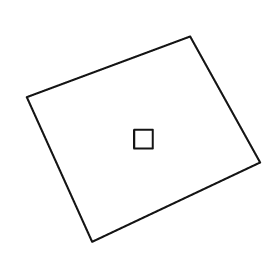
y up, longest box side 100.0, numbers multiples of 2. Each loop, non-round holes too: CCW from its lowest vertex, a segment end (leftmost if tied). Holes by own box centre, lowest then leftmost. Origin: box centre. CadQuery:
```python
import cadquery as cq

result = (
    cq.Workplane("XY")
    .moveTo(-22.0, -44.0)
    .lineTo(50.0, -10.0)
    .lineTo(20.0, 44.0)
    .lineTo(-50.0, 18.0)
    .close()
    .moveTo(-4.0, -4.0)
    .lineTo(4.0, -4.0)
    .lineTo(4.0, 4.0)
    .lineTo(-4.0, 4.0)
    .close()
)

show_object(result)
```